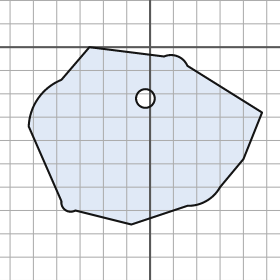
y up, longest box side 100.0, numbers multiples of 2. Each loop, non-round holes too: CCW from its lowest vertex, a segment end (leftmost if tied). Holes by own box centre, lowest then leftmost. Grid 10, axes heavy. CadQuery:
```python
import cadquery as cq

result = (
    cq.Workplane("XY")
    .moveTo(-8.0, -76.0)
    .lineTo(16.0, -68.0)
    .threePointArc((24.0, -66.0), (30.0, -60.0))
    .lineTo(40.0, -48.0)
    .lineTo(48.0, -28.0)
    .lineTo(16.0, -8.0)
    .threePointArc((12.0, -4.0), (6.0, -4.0))
    .lineTo(-26.0, 0.0)
    .lineTo(-38.0, -14.0)
    .threePointArc((-48.0, -22.0), (-52.0, -34.0))
    .lineTo(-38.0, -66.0)
    .threePointArc((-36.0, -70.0), (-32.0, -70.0))
    .close()
    .moveTo(-2.0, -22.0)
    .circle(4.0)
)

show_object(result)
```